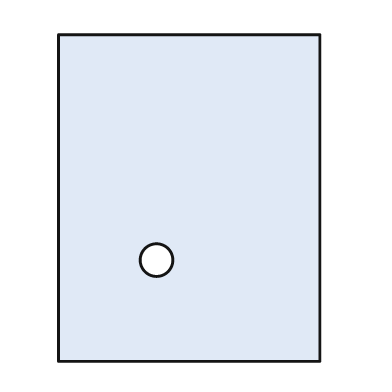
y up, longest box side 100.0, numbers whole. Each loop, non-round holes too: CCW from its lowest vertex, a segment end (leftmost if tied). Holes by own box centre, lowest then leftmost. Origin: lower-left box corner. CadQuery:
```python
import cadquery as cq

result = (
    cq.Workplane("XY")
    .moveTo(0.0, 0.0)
    .lineTo(80.0, 0.0)
    .lineTo(80.0, 100.0)
    .lineTo(0.0, 100.0)
    .close()
    .moveTo(30.0, 31.0)
    .circle(5.0)
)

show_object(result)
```